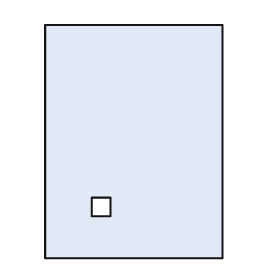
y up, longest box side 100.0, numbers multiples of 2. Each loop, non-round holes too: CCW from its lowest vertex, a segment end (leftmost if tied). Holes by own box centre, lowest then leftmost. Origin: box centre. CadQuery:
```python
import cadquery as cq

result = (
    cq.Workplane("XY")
    .moveTo(-38.0, -50.0)
    .lineTo(38.0, -50.0)
    .lineTo(38.0, 50.0)
    .lineTo(-38.0, 50.0)
    .close()
    .moveTo(-18.0, -32.0)
    .lineTo(-10.0, -32.0)
    .lineTo(-10.0, -24.0)
    .lineTo(-18.0, -24.0)
    .close()
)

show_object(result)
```